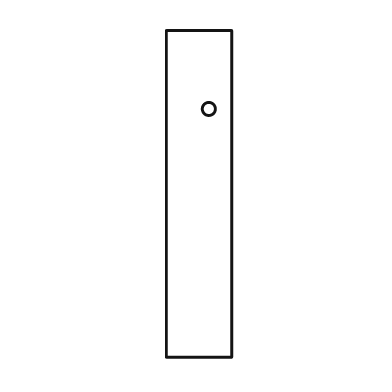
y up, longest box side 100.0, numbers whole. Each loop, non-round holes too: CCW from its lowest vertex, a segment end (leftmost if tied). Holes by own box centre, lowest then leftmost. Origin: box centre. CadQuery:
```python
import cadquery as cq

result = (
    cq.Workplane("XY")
    .moveTo(-10.0, -50.0)
    .lineTo(10.0, -50.0)
    .lineTo(10.0, 50.0)
    .lineTo(-10.0, 50.0)
    .close()
    .moveTo(3.0, 26.0)
    .circle(2.0)
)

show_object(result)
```